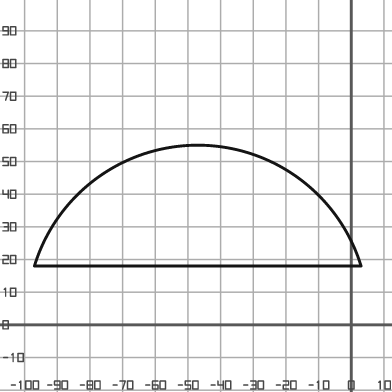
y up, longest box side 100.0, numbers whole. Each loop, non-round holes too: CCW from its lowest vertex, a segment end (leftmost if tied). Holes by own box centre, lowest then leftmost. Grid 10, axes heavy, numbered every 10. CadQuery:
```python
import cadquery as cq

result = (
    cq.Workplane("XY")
    .moveTo(-97.0, 18.0)
    .lineTo(3.0, 18.0)
    .threePointArc((-47.0, 55.0), (-97.0, 18.0))
    .close()
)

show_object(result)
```